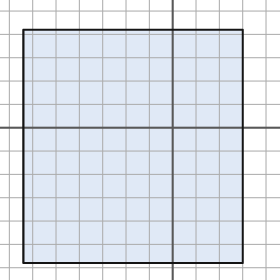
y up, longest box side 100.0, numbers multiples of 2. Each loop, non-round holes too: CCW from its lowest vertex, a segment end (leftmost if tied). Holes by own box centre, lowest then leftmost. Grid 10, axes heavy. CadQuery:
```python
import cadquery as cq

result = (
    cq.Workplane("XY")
    .moveTo(-64.0, -58.0)
    .lineTo(30.0, -58.0)
    .lineTo(30.0, 42.0)
    .lineTo(-64.0, 42.0)
    .close()
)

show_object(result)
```